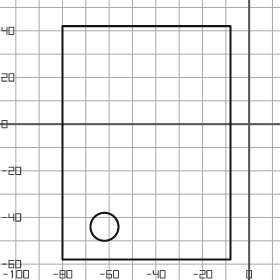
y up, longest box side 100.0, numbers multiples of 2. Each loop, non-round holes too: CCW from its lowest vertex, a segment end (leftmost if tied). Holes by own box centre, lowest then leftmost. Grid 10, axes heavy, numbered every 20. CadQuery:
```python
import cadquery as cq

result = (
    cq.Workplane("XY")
    .moveTo(-80.0, -58.0)
    .lineTo(-8.0, -58.0)
    .lineTo(-8.0, 42.0)
    .lineTo(-80.0, 42.0)
    .close()
    .moveTo(-62.0, -44.0)
    .circle(6.0)
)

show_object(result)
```